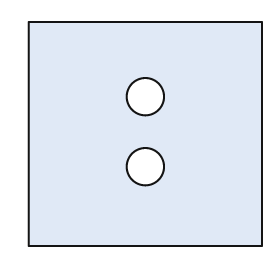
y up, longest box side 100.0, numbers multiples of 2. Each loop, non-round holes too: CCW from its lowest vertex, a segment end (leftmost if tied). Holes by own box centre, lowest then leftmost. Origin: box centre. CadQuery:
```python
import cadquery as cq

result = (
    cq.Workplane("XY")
    .moveTo(-50.0, -48.0)
    .lineTo(50.0, -48.0)
    .lineTo(50.0, 48.0)
    .lineTo(-50.0, 48.0)
    .close()
    .moveTo(0.0, -14.0)
    .circle(8.0)
    .moveTo(0.0, 16.0)
    .circle(8.0)
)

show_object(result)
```